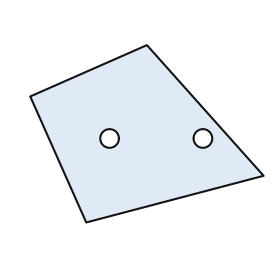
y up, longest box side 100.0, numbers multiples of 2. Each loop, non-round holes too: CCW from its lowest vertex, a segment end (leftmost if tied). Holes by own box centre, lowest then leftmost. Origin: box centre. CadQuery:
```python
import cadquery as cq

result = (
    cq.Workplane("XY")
    .moveTo(-26.0, -38.0)
    .lineTo(50.0, -18.0)
    .lineTo(0.0, 38.0)
    .lineTo(-50.0, 16.0)
    .close()
    .moveTo(-16.0, -2.0)
    .circle(4.0)
    .moveTo(24.0, -2.0)
    .circle(4.0)
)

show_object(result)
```